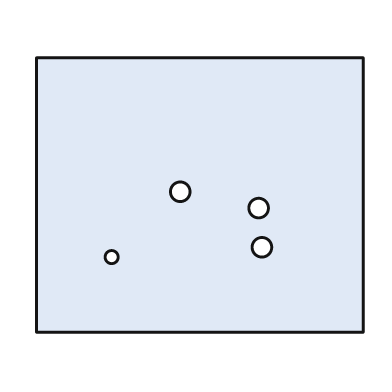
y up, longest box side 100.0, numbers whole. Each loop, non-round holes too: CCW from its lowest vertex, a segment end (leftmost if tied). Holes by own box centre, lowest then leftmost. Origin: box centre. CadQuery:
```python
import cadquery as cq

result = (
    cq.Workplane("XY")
    .moveTo(-50.0, -42.0)
    .lineTo(50.0, -42.0)
    .lineTo(50.0, 42.0)
    .lineTo(-50.0, 42.0)
    .close()
    .moveTo(-27.0, -19.0)
    .circle(2.0)
    .moveTo(19.0, -16.0)
    .circle(3.0)
    .moveTo(18.0, -4.0)
    .circle(3.0)
    .moveTo(-6.0, 1.0)
    .circle(3.0)
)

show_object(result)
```